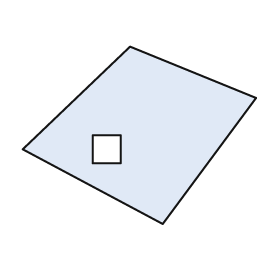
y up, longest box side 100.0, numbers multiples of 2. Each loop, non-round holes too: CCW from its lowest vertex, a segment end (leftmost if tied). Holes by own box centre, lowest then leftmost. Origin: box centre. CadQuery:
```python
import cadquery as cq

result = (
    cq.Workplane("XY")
    .moveTo(10.0, -38.0)
    .lineTo(50.0, 16.0)
    .lineTo(-4.0, 38.0)
    .lineTo(-50.0, -6.0)
    .close()
    .moveTo(-20.0, -12.0)
    .lineTo(-8.0, -12.0)
    .lineTo(-8.0, 0.0)
    .lineTo(-20.0, 0.0)
    .close()
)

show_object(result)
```